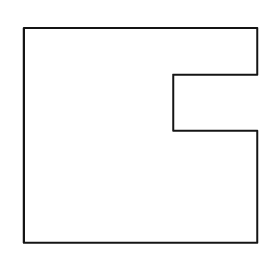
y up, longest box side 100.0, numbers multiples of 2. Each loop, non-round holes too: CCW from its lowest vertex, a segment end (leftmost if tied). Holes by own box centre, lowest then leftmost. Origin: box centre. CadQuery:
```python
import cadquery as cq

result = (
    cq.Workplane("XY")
    .moveTo(-50.0, -46.0)
    .lineTo(50.0, -46.0)
    .lineTo(50.0, 2.0)
    .lineTo(14.0, 2.0)
    .lineTo(14.0, 26.0)
    .lineTo(50.0, 26.0)
    .lineTo(50.0, 46.0)
    .lineTo(-50.0, 46.0)
    .close()
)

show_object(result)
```